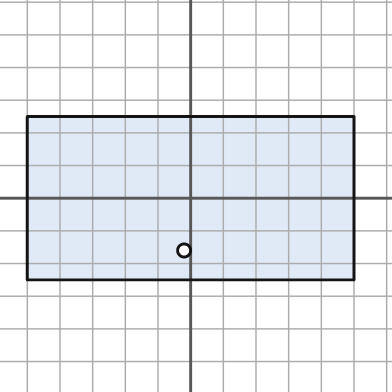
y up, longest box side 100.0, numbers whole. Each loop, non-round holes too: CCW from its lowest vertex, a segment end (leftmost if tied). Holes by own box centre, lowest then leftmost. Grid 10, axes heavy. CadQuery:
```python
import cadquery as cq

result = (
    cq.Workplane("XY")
    .moveTo(-50.0, -25.0)
    .lineTo(50.0, -25.0)
    .lineTo(50.0, 25.0)
    .lineTo(-50.0, 25.0)
    .close()
    .moveTo(-2.0, -16.0)
    .circle(2.0)
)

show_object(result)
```